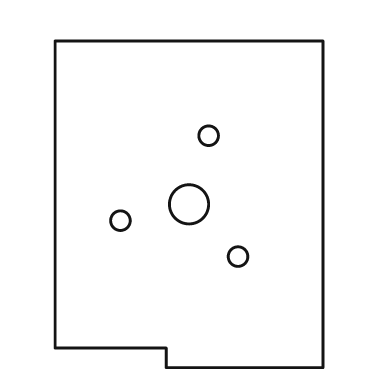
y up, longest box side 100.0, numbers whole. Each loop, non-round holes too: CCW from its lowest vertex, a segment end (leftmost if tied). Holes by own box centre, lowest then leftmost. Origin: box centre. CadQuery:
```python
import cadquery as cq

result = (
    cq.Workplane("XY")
    .moveTo(-7.0, -50.0)
    .lineTo(41.0, -50.0)
    .lineTo(41.0, 50.0)
    .lineTo(-41.0, 50.0)
    .lineTo(-41.0, -44.0)
    .lineTo(-7.0, -44.0)
    .close()
    .moveTo(15.0, -16.0)
    .circle(3.0)
    .moveTo(-21.0, -5.0)
    .circle(3.0)
    .moveTo(0.0, 0.0)
    .circle(6.0)
    .moveTo(6.0, 21.0)
    .circle(3.0)
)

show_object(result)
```